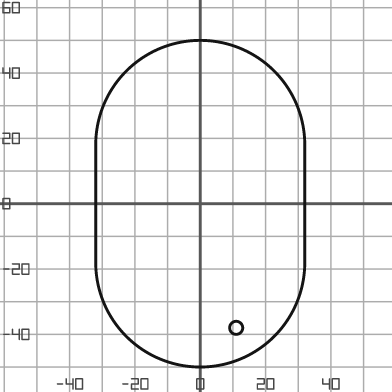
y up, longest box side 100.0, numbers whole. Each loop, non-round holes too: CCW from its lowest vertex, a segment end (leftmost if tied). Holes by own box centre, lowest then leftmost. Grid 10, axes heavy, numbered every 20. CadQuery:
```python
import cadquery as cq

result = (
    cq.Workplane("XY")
    .moveTo(-32.0, -18.0)
    .threePointArc((0.0, -50.0), (32.0, -18.0))
    .lineTo(32.0, 18.0)
    .threePointArc((0.0, 50.0), (-32.0, 18.0))
    .close()
    .moveTo(11.0, -38.0)
    .circle(2.0)
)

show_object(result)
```